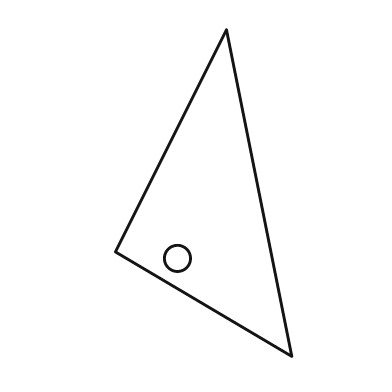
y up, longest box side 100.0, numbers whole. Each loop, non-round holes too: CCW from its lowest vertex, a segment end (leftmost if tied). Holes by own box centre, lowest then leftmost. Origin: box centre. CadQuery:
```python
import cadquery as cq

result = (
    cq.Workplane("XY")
    .moveTo(27.0, -50.0)
    .lineTo(7.0, 50.0)
    .lineTo(-27.0, -18.0)
    .close()
    .moveTo(-8.0, -20.0)
    .circle(4.0)
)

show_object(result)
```